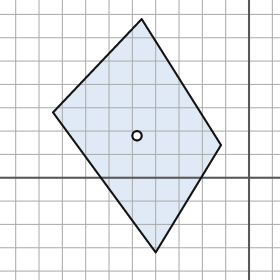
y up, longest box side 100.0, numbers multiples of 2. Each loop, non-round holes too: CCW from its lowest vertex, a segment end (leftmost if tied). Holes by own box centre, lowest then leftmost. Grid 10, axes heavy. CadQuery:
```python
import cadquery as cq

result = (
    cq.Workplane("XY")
    .moveTo(-40.0, -32.0)
    .lineTo(-12.0, 14.0)
    .lineTo(-46.0, 68.0)
    .lineTo(-84.0, 28.0)
    .close()
    .moveTo(-48.0, 18.0)
    .circle(2.0)
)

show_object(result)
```